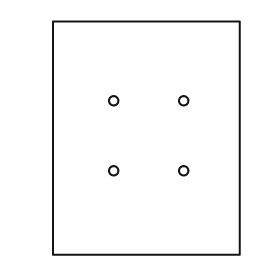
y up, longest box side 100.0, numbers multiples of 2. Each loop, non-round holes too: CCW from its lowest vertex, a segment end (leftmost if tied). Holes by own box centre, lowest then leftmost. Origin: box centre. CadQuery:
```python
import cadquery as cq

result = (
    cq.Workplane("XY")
    .moveTo(-40.0, -50.0)
    .lineTo(40.0, -50.0)
    .lineTo(40.0, 50.0)
    .lineTo(-40.0, 50.0)
    .close()
    .moveTo(-14.0, -14.0)
    .circle(2.0)
    .moveTo(16.0, -14.0)
    .circle(2.0)
    .moveTo(-14.0, 16.0)
    .circle(2.0)
    .moveTo(16.0, 16.0)
    .circle(2.0)
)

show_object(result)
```